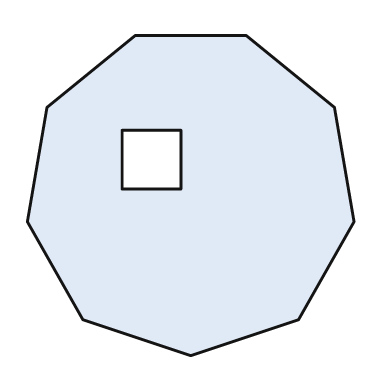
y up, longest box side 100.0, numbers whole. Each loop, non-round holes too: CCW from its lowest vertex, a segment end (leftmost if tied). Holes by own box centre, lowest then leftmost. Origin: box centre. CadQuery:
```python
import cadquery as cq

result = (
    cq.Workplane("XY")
    .moveTo(0.0, -49.0)
    .lineTo(33.0, -38.0)
    .lineTo(50.0, -8.0)
    .lineTo(44.0, 27.0)
    .lineTo(17.0, 49.0)
    .lineTo(-17.0, 49.0)
    .lineTo(-44.0, 27.0)
    .lineTo(-50.0, -8.0)
    .lineTo(-33.0, -38.0)
    .close()
    .moveTo(-21.0, 2.0)
    .lineTo(-3.0, 2.0)
    .lineTo(-3.0, 20.0)
    .lineTo(-21.0, 20.0)
    .close()
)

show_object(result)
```